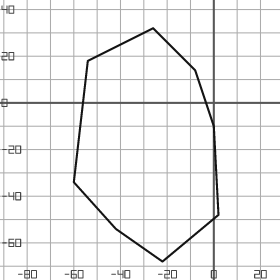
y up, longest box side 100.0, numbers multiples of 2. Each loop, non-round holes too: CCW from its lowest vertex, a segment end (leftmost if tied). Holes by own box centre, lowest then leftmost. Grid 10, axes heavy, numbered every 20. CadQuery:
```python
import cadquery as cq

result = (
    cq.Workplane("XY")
    .moveTo(-22.0, -68.0)
    .lineTo(2.0, -48.0)
    .lineTo(0.0, -10.0)
    .lineTo(-8.0, 14.0)
    .lineTo(-26.0, 32.0)
    .lineTo(-54.0, 18.0)
    .lineTo(-60.0, -34.0)
    .lineTo(-42.0, -54.0)
    .close()
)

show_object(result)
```